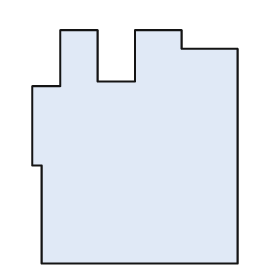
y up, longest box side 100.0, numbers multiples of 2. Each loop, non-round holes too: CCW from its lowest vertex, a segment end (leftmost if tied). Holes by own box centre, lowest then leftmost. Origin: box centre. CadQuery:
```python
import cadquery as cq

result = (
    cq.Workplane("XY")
    .moveTo(-40.0, -50.0)
    .lineTo(44.0, -50.0)
    .lineTo(44.0, 42.0)
    .lineTo(20.0, 42.0)
    .lineTo(20.0, 50.0)
    .lineTo(0.0, 50.0)
    .lineTo(0.0, 28.0)
    .lineTo(-16.0, 28.0)
    .lineTo(-16.0, 50.0)
    .lineTo(-32.0, 50.0)
    .lineTo(-32.0, 26.0)
    .lineTo(-44.0, 26.0)
    .lineTo(-44.0, -8.0)
    .lineTo(-40.0, -8.0)
    .close()
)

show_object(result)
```